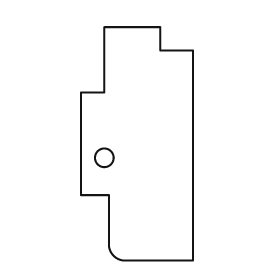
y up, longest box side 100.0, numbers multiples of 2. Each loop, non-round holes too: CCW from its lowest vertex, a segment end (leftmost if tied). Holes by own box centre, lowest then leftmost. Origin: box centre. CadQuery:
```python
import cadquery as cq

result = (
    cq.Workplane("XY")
    .moveTo(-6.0, -50.0)
    .lineTo(24.0, -50.0)
    .lineTo(24.0, 40.0)
    .lineTo(10.0, 40.0)
    .lineTo(10.0, 50.0)
    .lineTo(-14.0, 50.0)
    .lineTo(-14.0, 22.0)
    .lineTo(-24.0, 22.0)
    .lineTo(-24.0, -22.0)
    .lineTo(-12.0, -22.0)
    .lineTo(-12.0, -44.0)
    .threePointArc((-10.0, -48.0), (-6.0, -50.0))
    .close()
    .moveTo(-14.0, -6.0)
    .circle(4.0)
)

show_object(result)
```